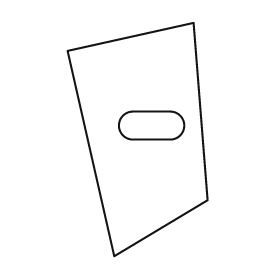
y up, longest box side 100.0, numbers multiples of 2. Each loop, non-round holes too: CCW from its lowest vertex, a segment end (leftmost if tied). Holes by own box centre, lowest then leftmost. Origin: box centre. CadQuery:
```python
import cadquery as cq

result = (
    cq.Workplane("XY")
    .moveTo(-10.0, -50.0)
    .lineTo(30.0, -26.0)
    .lineTo(24.0, 50.0)
    .lineTo(-30.0, 38.0)
    .close()
    .moveTo(-2.0, 0.0)
    .lineTo(14.0, 0.0)
    .threePointArc((20.0, 6.0), (14.0, 12.0))
    .lineTo(-2.0, 12.0)
    .threePointArc((-8.0, 6.0), (-2.0, 0.0))
    .close()
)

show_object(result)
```